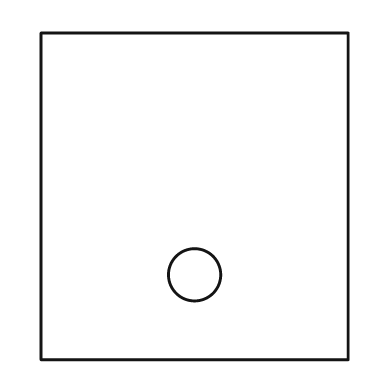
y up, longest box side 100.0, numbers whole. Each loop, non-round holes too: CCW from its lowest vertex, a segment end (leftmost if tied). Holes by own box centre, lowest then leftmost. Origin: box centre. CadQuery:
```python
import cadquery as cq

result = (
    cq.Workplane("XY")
    .moveTo(-47.0, -50.0)
    .lineTo(47.0, -50.0)
    .lineTo(47.0, 50.0)
    .lineTo(-47.0, 50.0)
    .close()
    .moveTo(0.0, -24.0)
    .circle(8.0)
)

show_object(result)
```